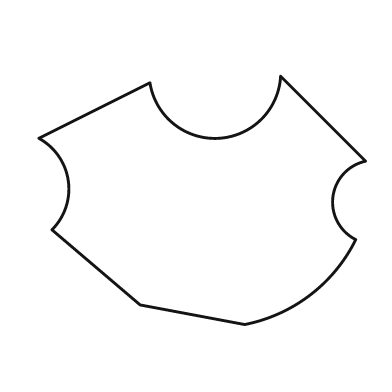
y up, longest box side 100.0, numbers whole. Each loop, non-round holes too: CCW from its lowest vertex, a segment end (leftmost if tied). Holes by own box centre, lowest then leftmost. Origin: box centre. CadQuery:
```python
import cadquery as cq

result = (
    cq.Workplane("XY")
    .moveTo(13.0, -38.0)
    .threePointArc((33.0, -29.0), (47.0, -12.0))
    .threePointArc((40.0, 1.0), (50.0, 12.0))
    .lineTo(24.0, 38.0)
    .threePointArc((5.0, 19.0), (-16.0, 36.0))
    .lineTo(-50.0, 19.0)
    .threePointArc((-41.0, 6.0), (-46.0, -9.0))
    .lineTo(-19.0, -32.0)
    .close()
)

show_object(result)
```